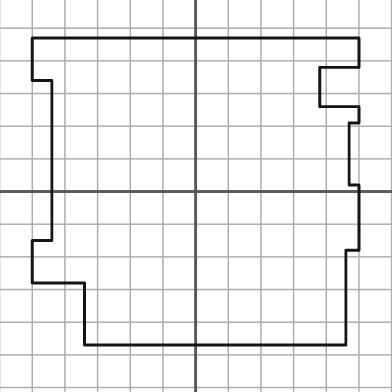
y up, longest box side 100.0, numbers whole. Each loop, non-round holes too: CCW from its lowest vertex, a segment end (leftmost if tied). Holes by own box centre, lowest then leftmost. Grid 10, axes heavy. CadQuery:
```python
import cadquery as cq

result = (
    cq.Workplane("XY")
    .moveTo(-34.0, -47.0)
    .lineTo(46.0, -47.0)
    .lineTo(46.0, -18.0)
    .lineTo(50.0, -18.0)
    .lineTo(50.0, 2.0)
    .lineTo(47.0, 2.0)
    .lineTo(47.0, 21.0)
    .lineTo(50.0, 21.0)
    .lineTo(50.0, 26.0)
    .lineTo(38.0, 26.0)
    .lineTo(38.0, 38.0)
    .lineTo(50.0, 38.0)
    .lineTo(50.0, 47.0)
    .lineTo(-50.0, 47.0)
    .lineTo(-50.0, 34.0)
    .lineTo(-44.0, 34.0)
    .lineTo(-44.0, -15.0)
    .lineTo(-50.0, -15.0)
    .lineTo(-50.0, -28.0)
    .lineTo(-34.0, -28.0)
    .close()
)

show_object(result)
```